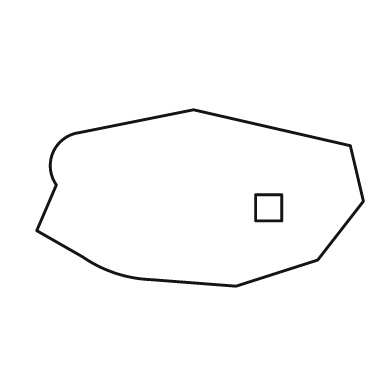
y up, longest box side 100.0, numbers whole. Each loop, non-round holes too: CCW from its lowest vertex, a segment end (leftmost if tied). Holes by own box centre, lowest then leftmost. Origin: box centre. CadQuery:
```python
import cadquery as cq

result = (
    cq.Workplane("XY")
    .moveTo(11.0, -27.0)
    .lineTo(36.0, -19.0)
    .lineTo(50.0, -1.0)
    .lineTo(46.0, 16.0)
    .lineTo(-2.0, 27.0)
    .lineTo(-37.0, 20.0)
    .threePointArc((-45.0, 14.0), (-44.0, 4.0))
    .lineTo(-50.0, -10.0)
    .lineTo(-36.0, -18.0)
    .threePointArc((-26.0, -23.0), (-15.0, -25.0))
    .close()
    .moveTo(17.0, -7.0)
    .lineTo(25.0, -7.0)
    .lineTo(25.0, 1.0)
    .lineTo(17.0, 1.0)
    .close()
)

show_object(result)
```